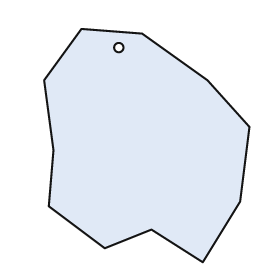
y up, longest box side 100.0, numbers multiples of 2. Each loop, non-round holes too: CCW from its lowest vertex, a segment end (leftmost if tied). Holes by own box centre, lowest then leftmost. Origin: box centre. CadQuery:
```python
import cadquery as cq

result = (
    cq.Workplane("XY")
    .moveTo(24.0, -50.0)
    .lineTo(40.0, -24.0)
    .lineTo(44.0, 8.0)
    .lineTo(26.0, 28.0)
    .lineTo(-2.0, 48.0)
    .lineTo(-28.0, 50.0)
    .lineTo(-44.0, 28.0)
    .lineTo(-40.0, -2.0)
    .lineTo(-42.0, -26.0)
    .lineTo(-18.0, -44.0)
    .lineTo(2.0, -36.0)
    .close()
    .moveTo(-12.0, 42.0)
    .circle(2.0)
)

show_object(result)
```